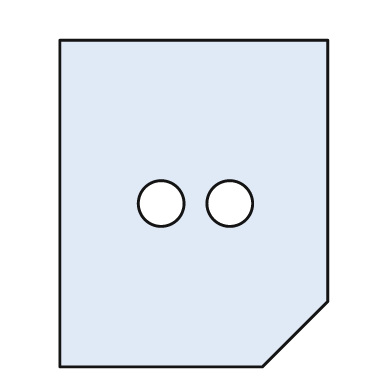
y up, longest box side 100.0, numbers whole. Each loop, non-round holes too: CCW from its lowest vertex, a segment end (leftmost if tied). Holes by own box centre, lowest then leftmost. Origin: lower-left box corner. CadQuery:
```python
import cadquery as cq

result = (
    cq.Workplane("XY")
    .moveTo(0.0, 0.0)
    .lineTo(62.0, 0.0)
    .lineTo(82.0, 20.0)
    .lineTo(82.0, 100.0)
    .lineTo(0.0, 100.0)
    .close()
    .moveTo(31.0, 50.0)
    .circle(7.0)
    .moveTo(52.0, 50.0)
    .circle(7.0)
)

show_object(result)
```